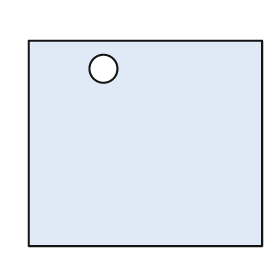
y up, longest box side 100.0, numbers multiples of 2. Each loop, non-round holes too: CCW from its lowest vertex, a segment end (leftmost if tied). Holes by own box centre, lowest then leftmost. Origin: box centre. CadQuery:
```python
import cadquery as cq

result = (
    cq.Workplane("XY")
    .moveTo(-50.0, -44.0)
    .lineTo(50.0, -44.0)
    .lineTo(50.0, 44.0)
    .lineTo(-50.0, 44.0)
    .close()
    .moveTo(-18.0, 32.0)
    .circle(6.0)
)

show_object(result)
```